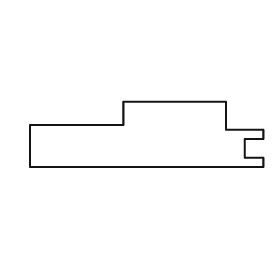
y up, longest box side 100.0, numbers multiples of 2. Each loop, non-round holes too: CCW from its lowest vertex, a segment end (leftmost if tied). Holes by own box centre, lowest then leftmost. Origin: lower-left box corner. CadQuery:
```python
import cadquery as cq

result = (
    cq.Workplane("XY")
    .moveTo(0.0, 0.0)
    .lineTo(100.0, 0.0)
    .lineTo(100.0, 4.0)
    .lineTo(92.0, 4.0)
    .lineTo(92.0, 12.0)
    .lineTo(100.0, 12.0)
    .lineTo(100.0, 16.0)
    .lineTo(84.0, 16.0)
    .lineTo(84.0, 28.0)
    .lineTo(40.0, 28.0)
    .lineTo(40.0, 18.0)
    .lineTo(0.0, 18.0)
    .close()
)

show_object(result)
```